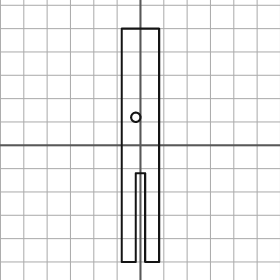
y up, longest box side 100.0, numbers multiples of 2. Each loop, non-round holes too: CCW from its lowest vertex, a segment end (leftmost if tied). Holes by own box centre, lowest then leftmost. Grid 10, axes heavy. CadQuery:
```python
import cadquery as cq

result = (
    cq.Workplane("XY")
    .moveTo(-8.0, -50.0)
    .lineTo(-2.0, -50.0)
    .lineTo(-2.0, -12.0)
    .lineTo(2.0, -12.0)
    .lineTo(2.0, -50.0)
    .lineTo(8.0, -50.0)
    .lineTo(8.0, 50.0)
    .lineTo(-8.0, 50.0)
    .close()
    .moveTo(-2.0, 12.0)
    .circle(2.0)
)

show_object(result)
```